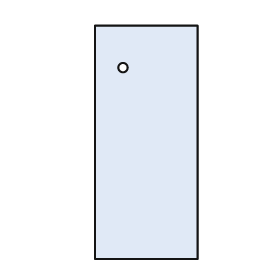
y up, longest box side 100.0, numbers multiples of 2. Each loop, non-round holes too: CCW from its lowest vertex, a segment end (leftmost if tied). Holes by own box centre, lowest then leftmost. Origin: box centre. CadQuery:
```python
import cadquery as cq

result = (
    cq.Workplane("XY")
    .moveTo(-22.0, -50.0)
    .lineTo(22.0, -50.0)
    .lineTo(22.0, 50.0)
    .lineTo(-22.0, 50.0)
    .close()
    .moveTo(-10.0, 32.0)
    .circle(2.0)
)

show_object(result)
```